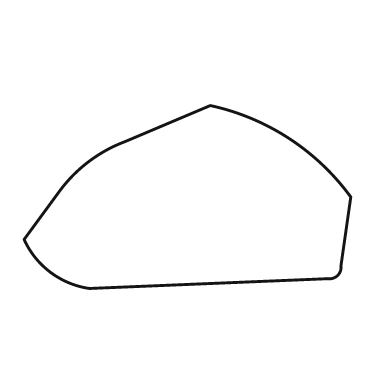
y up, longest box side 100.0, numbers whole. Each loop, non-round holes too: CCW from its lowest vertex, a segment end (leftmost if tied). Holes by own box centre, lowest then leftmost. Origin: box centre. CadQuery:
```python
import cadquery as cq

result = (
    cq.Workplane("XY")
    .moveTo(-30.0, -28.0)
    .lineTo(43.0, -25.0)
    .threePointArc((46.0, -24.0), (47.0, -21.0))
    .lineTo(50.0, 0.0)
    .threePointArc((31.0, 18.0), (7.0, 28.0))
    .lineTo(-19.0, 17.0)
    .threePointArc((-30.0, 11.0), (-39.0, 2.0))
    .lineTo(-50.0, -13.0)
    .threePointArc((-42.0, -23.0), (-30.0, -28.0))
    .close()
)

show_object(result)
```